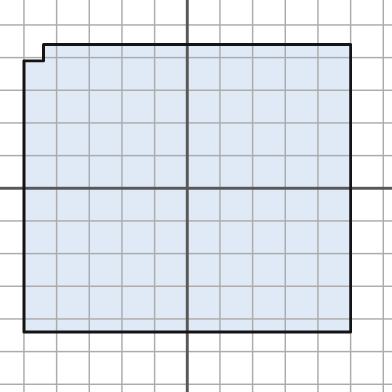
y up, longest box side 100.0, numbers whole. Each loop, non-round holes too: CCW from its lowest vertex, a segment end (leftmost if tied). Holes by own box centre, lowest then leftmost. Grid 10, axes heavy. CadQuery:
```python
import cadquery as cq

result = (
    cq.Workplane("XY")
    .moveTo(-50.0, -44.0)
    .lineTo(50.0, -44.0)
    .lineTo(50.0, 44.0)
    .lineTo(-44.0, 44.0)
    .lineTo(-44.0, 39.0)
    .lineTo(-50.0, 39.0)
    .close()
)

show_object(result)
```